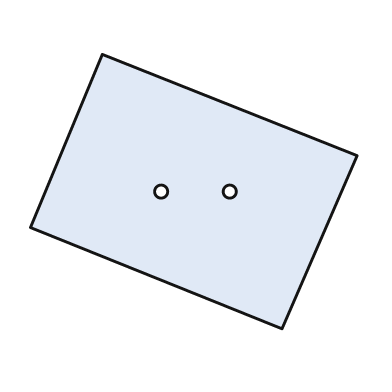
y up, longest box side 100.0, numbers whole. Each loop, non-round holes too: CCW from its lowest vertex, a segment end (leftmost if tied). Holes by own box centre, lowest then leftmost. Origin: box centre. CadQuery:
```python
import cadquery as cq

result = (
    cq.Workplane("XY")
    .moveTo(27.0, -42.0)
    .lineTo(50.0, 11.0)
    .lineTo(-28.0, 42.0)
    .lineTo(-50.0, -11.0)
    .close()
    .moveTo(-10.0, 0.0)
    .circle(2.0)
    .moveTo(11.0, 0.0)
    .circle(2.0)
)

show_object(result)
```